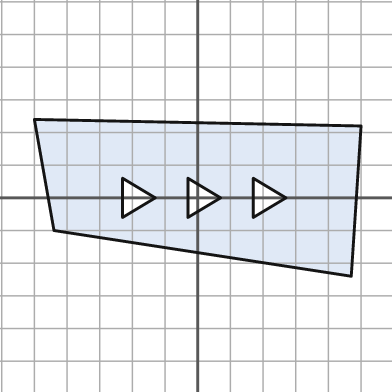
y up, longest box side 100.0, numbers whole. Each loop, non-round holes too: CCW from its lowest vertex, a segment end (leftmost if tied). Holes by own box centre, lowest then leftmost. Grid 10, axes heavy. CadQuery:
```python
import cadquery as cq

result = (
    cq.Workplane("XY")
    .moveTo(47.0, -24.0)
    .lineTo(50.0, 22.0)
    .lineTo(-50.0, 24.0)
    .lineTo(-44.0, -10.0)
    .close()
    .moveTo(-23.0, -6.0)
    .lineTo(-13.0, 0.0)
    .lineTo(-23.0, 6.0)
    .close()
    .moveTo(-3.0, -6.0)
    .lineTo(7.0, 0.0)
    .lineTo(-3.0, 6.0)
    .close()
    .moveTo(17.0, -6.0)
    .lineTo(27.0, 0.0)
    .lineTo(17.0, 6.0)
    .close()
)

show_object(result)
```